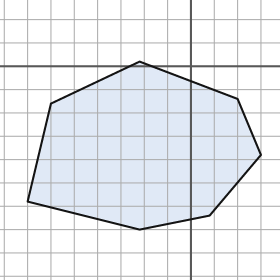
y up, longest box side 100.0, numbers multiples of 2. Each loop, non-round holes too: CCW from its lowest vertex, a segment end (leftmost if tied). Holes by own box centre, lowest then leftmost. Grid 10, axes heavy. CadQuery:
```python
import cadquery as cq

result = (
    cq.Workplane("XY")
    .moveTo(-22.0, -70.0)
    .lineTo(8.0, -64.0)
    .lineTo(30.0, -38.0)
    .lineTo(20.0, -14.0)
    .lineTo(-22.0, 2.0)
    .lineTo(-60.0, -16.0)
    .lineTo(-70.0, -58.0)
    .close()
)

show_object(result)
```